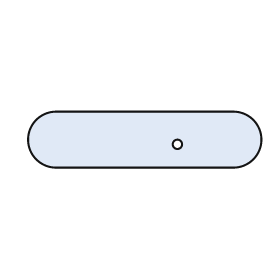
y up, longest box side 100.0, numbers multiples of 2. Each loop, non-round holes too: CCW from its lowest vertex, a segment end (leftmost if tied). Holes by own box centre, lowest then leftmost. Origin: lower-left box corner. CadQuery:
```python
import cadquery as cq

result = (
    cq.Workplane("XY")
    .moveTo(12.0, 0.0)
    .lineTo(88.0, 0.0)
    .threePointArc((100.0, 12.0), (88.0, 24.0))
    .lineTo(12.0, 24.0)
    .threePointArc((0.0, 12.0), (12.0, 0.0))
    .close()
    .moveTo(64.0, 10.0)
    .circle(2.0)
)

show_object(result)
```